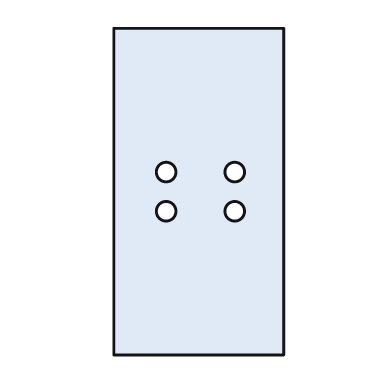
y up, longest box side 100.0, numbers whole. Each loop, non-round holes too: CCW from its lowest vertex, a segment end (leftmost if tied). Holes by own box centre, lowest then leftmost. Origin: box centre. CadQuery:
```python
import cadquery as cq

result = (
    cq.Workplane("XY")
    .moveTo(-26.0, -50.0)
    .lineTo(26.0, -50.0)
    .lineTo(26.0, 50.0)
    .lineTo(-26.0, 50.0)
    .close()
    .moveTo(-10.0, -6.0)
    .circle(3.0)
    .moveTo(11.0, -6.0)
    .circle(3.0)
    .moveTo(-10.0, 6.0)
    .circle(3.0)
    .moveTo(11.0, 6.0)
    .circle(3.0)
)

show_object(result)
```